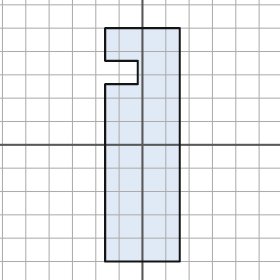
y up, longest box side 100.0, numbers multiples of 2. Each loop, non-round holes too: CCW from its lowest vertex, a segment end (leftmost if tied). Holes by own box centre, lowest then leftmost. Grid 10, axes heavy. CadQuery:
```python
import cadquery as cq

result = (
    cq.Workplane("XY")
    .moveTo(-16.0, -50.0)
    .lineTo(16.0, -50.0)
    .lineTo(16.0, 50.0)
    .lineTo(-16.0, 50.0)
    .lineTo(-16.0, 36.0)
    .lineTo(-2.0, 36.0)
    .lineTo(-2.0, 26.0)
    .lineTo(-16.0, 26.0)
    .close()
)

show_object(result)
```